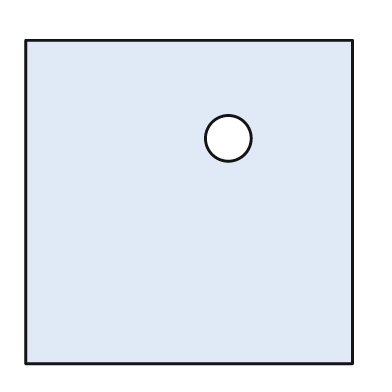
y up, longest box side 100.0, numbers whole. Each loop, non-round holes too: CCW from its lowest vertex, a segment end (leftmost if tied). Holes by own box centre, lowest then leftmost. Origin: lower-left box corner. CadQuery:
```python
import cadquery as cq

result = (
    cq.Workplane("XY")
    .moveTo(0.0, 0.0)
    .lineTo(100.0, 0.0)
    .lineTo(100.0, 99.0)
    .lineTo(0.0, 99.0)
    .close()
    .moveTo(62.0, 69.0)
    .circle(7.0)
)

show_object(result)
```